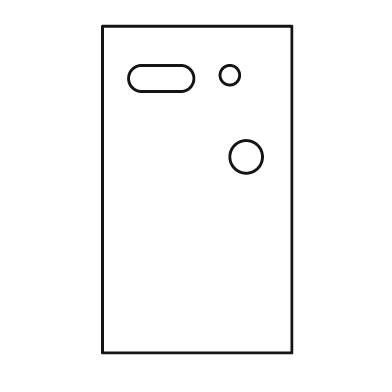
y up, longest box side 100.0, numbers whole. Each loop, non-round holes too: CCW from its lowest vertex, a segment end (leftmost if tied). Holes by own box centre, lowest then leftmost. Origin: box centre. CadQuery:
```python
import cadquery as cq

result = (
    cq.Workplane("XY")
    .moveTo(-29.0, -50.0)
    .lineTo(29.0, -50.0)
    .lineTo(29.0, 50.0)
    .lineTo(-29.0, 50.0)
    .close()
    .moveTo(15.0, 10.0)
    .circle(5.0)
    .moveTo(-17.0, 30.0)
    .lineTo(-5.0, 30.0)
    .threePointArc((-1.0, 34.0), (-5.0, 38.0))
    .lineTo(-17.0, 38.0)
    .threePointArc((-21.0, 34.0), (-17.0, 30.0))
    .close()
    .moveTo(10.0, 35.0)
    .circle(3.0)
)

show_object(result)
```